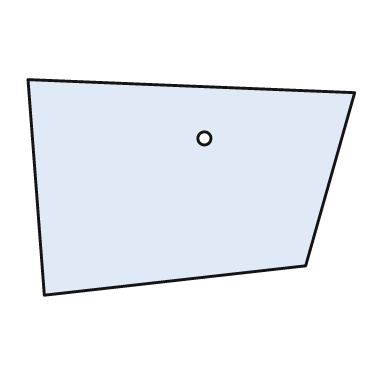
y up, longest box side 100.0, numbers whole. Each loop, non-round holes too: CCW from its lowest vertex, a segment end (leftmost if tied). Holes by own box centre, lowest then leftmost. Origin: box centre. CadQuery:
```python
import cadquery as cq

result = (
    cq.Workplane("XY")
    .moveTo(-45.0, -33.0)
    .lineTo(35.0, -24.0)
    .lineTo(50.0, 29.0)
    .lineTo(-50.0, 33.0)
    .close()
    .moveTo(4.0, 15.0)
    .circle(2.0)
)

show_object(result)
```